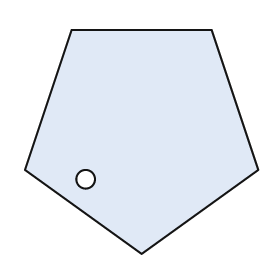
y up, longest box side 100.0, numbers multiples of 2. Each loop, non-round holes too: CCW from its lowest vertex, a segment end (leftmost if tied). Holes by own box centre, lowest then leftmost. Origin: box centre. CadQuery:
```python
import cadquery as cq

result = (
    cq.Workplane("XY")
    .moveTo(0.0, -48.0)
    .lineTo(50.0, -12.0)
    .lineTo(30.0, 48.0)
    .lineTo(-30.0, 48.0)
    .lineTo(-50.0, -12.0)
    .close()
    .moveTo(-24.0, -16.0)
    .circle(4.0)
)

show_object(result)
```